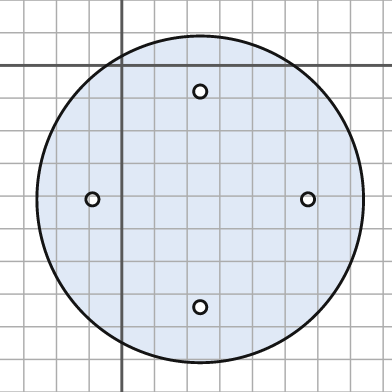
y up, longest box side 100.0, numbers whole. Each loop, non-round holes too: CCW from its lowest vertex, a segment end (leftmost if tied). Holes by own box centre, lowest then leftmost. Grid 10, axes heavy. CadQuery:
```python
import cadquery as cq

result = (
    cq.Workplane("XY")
    .moveTo(24.0, -41.0)
    .circle(50.0)
    .moveTo(24.0, -74.0)
    .circle(2.0)
    .moveTo(-9.0, -41.0)
    .circle(2.0)
    .moveTo(57.0, -41.0)
    .circle(2.0)
    .moveTo(24.0, -8.0)
    .circle(2.0)
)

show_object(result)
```